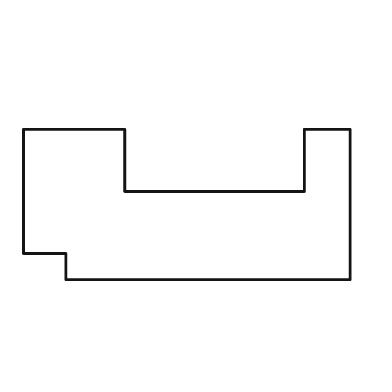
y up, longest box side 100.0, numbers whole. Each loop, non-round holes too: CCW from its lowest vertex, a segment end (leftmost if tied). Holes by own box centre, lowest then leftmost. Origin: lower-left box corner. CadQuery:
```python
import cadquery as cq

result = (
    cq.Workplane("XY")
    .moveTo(13.0, 0.0)
    .lineTo(100.0, 0.0)
    .lineTo(100.0, 46.0)
    .lineTo(86.0, 46.0)
    .lineTo(86.0, 27.0)
    .lineTo(31.0, 27.0)
    .lineTo(31.0, 46.0)
    .lineTo(0.0, 46.0)
    .lineTo(0.0, 8.0)
    .lineTo(13.0, 8.0)
    .close()
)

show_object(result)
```